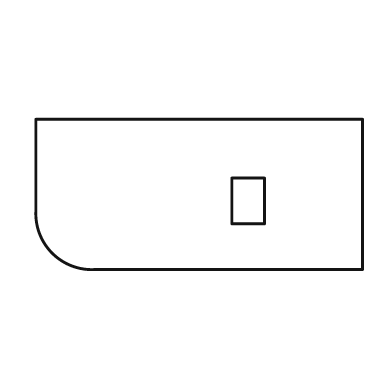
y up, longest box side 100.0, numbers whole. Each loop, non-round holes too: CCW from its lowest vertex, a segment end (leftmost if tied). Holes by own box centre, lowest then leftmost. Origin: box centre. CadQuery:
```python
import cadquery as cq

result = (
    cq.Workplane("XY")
    .moveTo(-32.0, -23.0)
    .lineTo(50.0, -23.0)
    .lineTo(50.0, 23.0)
    .lineTo(-50.0, 23.0)
    .lineTo(-50.0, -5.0)
    .threePointArc((-45.0, -18.0), (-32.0, -23.0))
    .close()
    .moveTo(10.0, -9.0)
    .lineTo(20.0, -9.0)
    .lineTo(20.0, 5.0)
    .lineTo(10.0, 5.0)
    .close()
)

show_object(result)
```